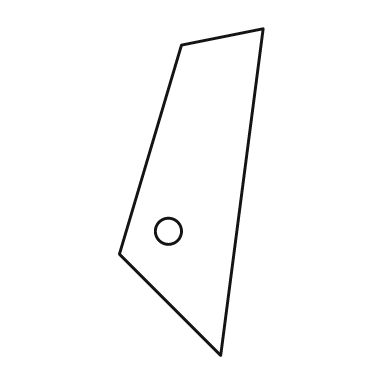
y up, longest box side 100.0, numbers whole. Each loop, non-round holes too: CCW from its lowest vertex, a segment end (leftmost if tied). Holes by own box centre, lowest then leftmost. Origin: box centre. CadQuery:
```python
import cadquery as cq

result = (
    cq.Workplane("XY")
    .moveTo(9.0, -50.0)
    .lineTo(22.0, 50.0)
    .lineTo(-3.0, 45.0)
    .lineTo(-22.0, -19.0)
    .close()
    .moveTo(-7.0, -12.0)
    .circle(4.0)
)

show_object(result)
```